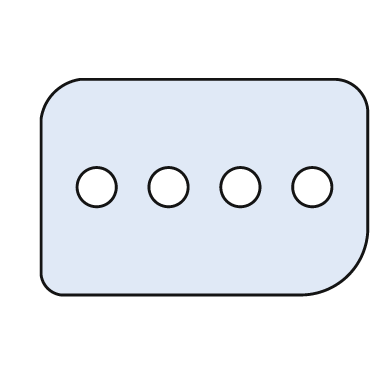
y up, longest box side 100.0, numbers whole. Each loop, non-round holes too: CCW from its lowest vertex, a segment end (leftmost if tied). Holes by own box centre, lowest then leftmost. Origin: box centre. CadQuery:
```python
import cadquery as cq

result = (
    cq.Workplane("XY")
    .moveTo(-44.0, -33.0)
    .lineTo(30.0, -33.0)
    .threePointArc((44.0, -27.0), (50.0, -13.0))
    .lineTo(50.0, 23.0)
    .threePointArc((47.0, 30.0), (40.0, 33.0))
    .lineTo(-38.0, 33.0)
    .threePointArc((-46.0, 29.0), (-50.0, 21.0))
    .lineTo(-50.0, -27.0)
    .threePointArc((-48.0, -31.0), (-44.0, -33.0))
    .close()
    .moveTo(-33.0, 0.0)
    .circle(6.0)
    .moveTo(-11.0, 0.0)
    .circle(6.0)
    .moveTo(11.0, 0.0)
    .circle(6.0)
    .moveTo(33.0, 0.0)
    .circle(6.0)
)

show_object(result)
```